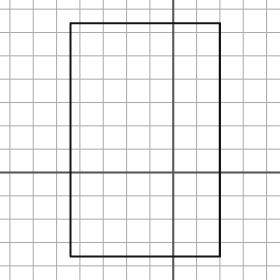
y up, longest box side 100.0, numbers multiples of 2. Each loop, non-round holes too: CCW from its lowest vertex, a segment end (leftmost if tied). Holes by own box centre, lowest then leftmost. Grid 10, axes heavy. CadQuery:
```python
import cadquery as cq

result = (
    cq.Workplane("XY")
    .moveTo(-44.0, -36.0)
    .lineTo(20.0, -36.0)
    .lineTo(20.0, 64.0)
    .lineTo(-44.0, 64.0)
    .close()
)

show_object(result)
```